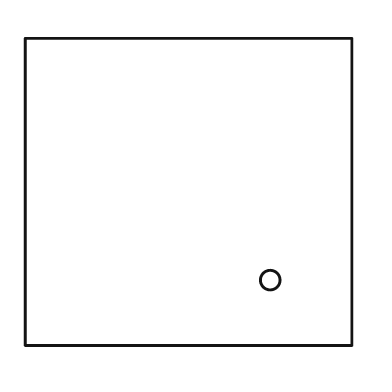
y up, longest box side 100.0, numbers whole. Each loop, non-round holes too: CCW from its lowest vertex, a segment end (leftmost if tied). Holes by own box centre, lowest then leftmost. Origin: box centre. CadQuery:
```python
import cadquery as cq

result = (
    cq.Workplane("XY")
    .moveTo(-50.0, -47.0)
    .lineTo(50.0, -47.0)
    .lineTo(50.0, 47.0)
    .lineTo(-50.0, 47.0)
    .close()
    .moveTo(25.0, -27.0)
    .circle(3.0)
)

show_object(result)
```